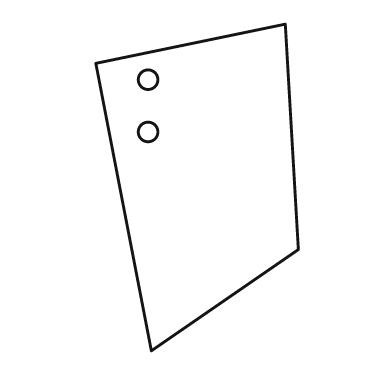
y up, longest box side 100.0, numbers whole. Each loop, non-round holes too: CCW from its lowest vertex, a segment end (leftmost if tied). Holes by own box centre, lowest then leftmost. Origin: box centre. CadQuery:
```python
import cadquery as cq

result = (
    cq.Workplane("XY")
    .moveTo(-14.0, -50.0)
    .lineTo(31.0, -19.0)
    .lineTo(27.0, 50.0)
    .lineTo(-31.0, 38.0)
    .close()
    .moveTo(-15.0, 17.0)
    .circle(3.0)
    .moveTo(-15.0, 33.0)
    .circle(3.0)
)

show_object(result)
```